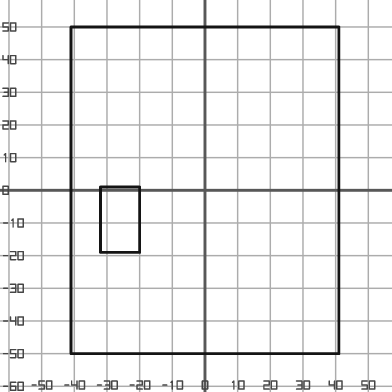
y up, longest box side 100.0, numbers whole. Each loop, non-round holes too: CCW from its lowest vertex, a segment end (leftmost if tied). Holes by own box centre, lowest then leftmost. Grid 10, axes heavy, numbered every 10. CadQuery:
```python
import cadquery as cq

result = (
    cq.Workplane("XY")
    .moveTo(-41.0, -50.0)
    .lineTo(41.0, -50.0)
    .lineTo(41.0, 50.0)
    .lineTo(-41.0, 50.0)
    .close()
    .moveTo(-32.0, -19.0)
    .lineTo(-20.0, -19.0)
    .lineTo(-20.0, 1.0)
    .lineTo(-32.0, 1.0)
    .close()
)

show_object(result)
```